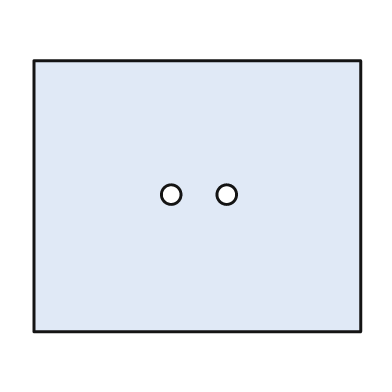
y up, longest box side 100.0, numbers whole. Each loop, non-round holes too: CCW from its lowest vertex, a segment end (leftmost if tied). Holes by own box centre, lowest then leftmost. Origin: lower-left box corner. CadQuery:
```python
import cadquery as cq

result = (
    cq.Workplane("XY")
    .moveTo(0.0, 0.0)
    .lineTo(100.0, 0.0)
    .lineTo(100.0, 83.0)
    .lineTo(0.0, 83.0)
    .close()
    .moveTo(42.0, 42.0)
    .circle(3.0)
    .moveTo(59.0, 42.0)
    .circle(3.0)
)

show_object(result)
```